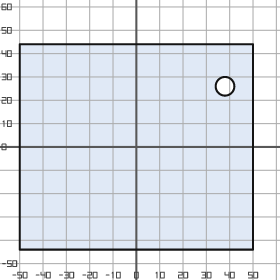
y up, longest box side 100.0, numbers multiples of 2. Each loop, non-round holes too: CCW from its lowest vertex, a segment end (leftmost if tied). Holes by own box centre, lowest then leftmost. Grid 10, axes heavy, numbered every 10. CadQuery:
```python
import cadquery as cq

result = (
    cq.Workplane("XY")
    .moveTo(-50.0, -44.0)
    .lineTo(50.0, -44.0)
    .lineTo(50.0, 44.0)
    .lineTo(-50.0, 44.0)
    .close()
    .moveTo(38.0, 26.0)
    .circle(4.0)
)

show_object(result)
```